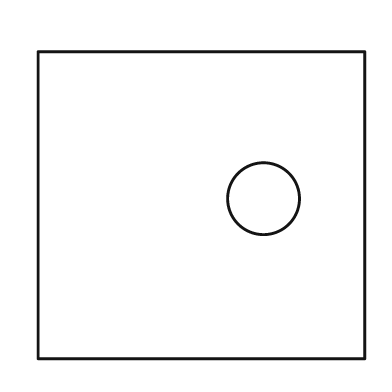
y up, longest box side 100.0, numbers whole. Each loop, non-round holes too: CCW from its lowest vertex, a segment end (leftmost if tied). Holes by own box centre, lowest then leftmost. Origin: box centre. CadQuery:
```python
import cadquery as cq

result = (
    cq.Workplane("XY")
    .moveTo(-50.0, -47.0)
    .lineTo(50.0, -47.0)
    .lineTo(50.0, 47.0)
    .lineTo(-50.0, 47.0)
    .close()
    .moveTo(19.0, 2.0)
    .circle(11.0)
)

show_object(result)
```